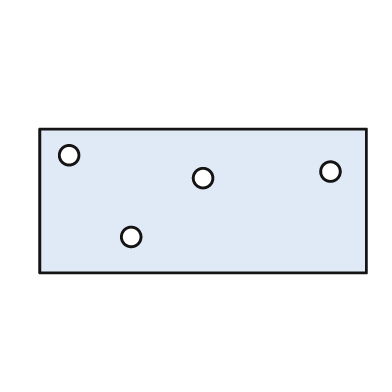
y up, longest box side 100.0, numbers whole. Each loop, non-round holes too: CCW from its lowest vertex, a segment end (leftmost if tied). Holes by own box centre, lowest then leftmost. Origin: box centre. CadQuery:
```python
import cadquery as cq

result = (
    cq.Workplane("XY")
    .moveTo(-50.0, -22.0)
    .lineTo(50.0, -22.0)
    .lineTo(50.0, 22.0)
    .lineTo(-50.0, 22.0)
    .close()
    .moveTo(-22.0, -11.0)
    .circle(3.0)
    .moveTo(0.0, 7.0)
    .circle(3.0)
    .moveTo(39.0, 9.0)
    .circle(3.0)
    .moveTo(-41.0, 14.0)
    .circle(3.0)
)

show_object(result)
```